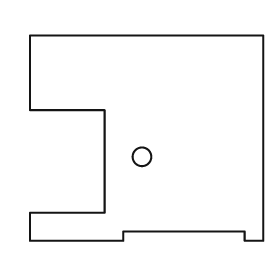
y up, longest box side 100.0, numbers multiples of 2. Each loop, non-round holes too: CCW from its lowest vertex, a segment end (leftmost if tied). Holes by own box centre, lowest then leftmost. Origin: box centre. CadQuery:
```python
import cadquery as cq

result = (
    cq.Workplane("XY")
    .moveTo(-50.0, -44.0)
    .lineTo(-10.0, -44.0)
    .lineTo(-10.0, -40.0)
    .lineTo(42.0, -40.0)
    .lineTo(42.0, -44.0)
    .lineTo(50.0, -44.0)
    .lineTo(50.0, 44.0)
    .lineTo(-50.0, 44.0)
    .lineTo(-50.0, 12.0)
    .lineTo(-18.0, 12.0)
    .lineTo(-18.0, -32.0)
    .lineTo(-50.0, -32.0)
    .close()
    .moveTo(-2.0, -8.0)
    .circle(4.0)
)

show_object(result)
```